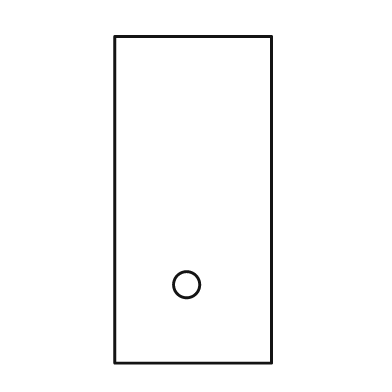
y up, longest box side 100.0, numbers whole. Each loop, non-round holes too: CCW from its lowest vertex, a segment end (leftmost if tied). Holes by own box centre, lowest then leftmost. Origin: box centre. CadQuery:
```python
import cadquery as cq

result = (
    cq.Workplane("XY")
    .moveTo(-24.0, -50.0)
    .lineTo(24.0, -50.0)
    .lineTo(24.0, 50.0)
    .lineTo(-24.0, 50.0)
    .close()
    .moveTo(-2.0, -26.0)
    .circle(4.0)
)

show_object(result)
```